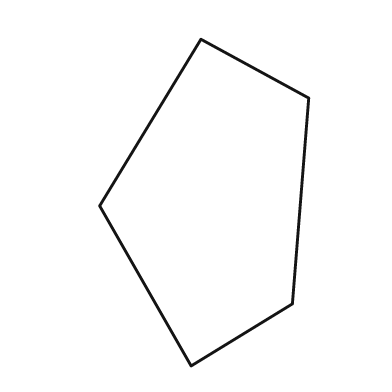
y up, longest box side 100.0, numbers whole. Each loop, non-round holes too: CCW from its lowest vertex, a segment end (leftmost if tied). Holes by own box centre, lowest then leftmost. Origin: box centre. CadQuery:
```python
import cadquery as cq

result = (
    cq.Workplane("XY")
    .moveTo(-4.0, -50.0)
    .lineTo(27.0, -31.0)
    .lineTo(32.0, 32.0)
    .lineTo(-1.0, 50.0)
    .lineTo(-32.0, -1.0)
    .close()
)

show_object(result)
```